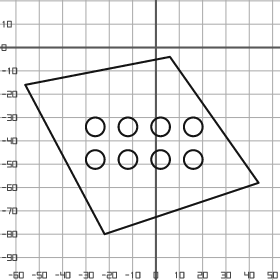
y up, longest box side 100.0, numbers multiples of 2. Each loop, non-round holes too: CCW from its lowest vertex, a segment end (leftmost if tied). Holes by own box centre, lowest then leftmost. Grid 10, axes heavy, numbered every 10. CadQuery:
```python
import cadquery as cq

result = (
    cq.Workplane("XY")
    .moveTo(-22.0, -80.0)
    .lineTo(44.0, -58.0)
    .lineTo(6.0, -4.0)
    .lineTo(-56.0, -16.0)
    .close()
    .moveTo(-26.0, -48.0)
    .circle(4.0)
    .moveTo(-12.0, -48.0)
    .circle(4.0)
    .moveTo(2.0, -48.0)
    .circle(4.0)
    .moveTo(16.0, -48.0)
    .circle(4.0)
    .moveTo(-26.0, -34.0)
    .circle(4.0)
    .moveTo(-12.0, -34.0)
    .circle(4.0)
    .moveTo(2.0, -34.0)
    .circle(4.0)
    .moveTo(16.0, -34.0)
    .circle(4.0)
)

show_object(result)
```